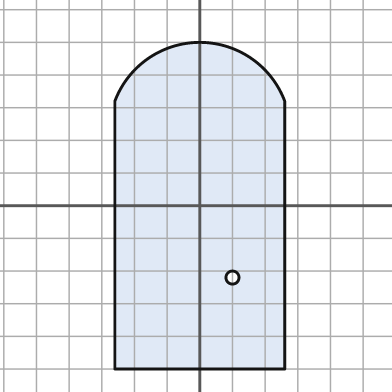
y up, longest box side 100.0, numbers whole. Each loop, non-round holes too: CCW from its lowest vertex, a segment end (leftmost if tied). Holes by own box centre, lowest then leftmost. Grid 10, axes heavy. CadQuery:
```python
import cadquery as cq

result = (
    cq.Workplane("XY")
    .moveTo(-26.0, -50.0)
    .lineTo(26.0, -50.0)
    .lineTo(26.0, 32.0)
    .threePointArc((0.0, 50.0), (-26.0, 32.0))
    .close()
    .moveTo(10.0, -22.0)
    .circle(2.0)
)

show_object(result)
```